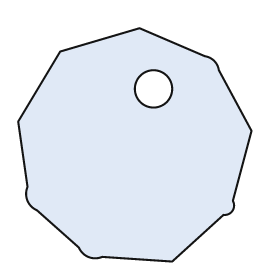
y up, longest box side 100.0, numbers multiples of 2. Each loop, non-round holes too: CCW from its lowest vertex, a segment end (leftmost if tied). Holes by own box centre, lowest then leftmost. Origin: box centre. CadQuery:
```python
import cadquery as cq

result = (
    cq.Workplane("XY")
    .moveTo(16.0, -50.0)
    .lineTo(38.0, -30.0)
    .threePointArc((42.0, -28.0), (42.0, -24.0))
    .lineTo(50.0, 6.0)
    .lineTo(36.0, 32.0)
    .threePointArc((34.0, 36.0), (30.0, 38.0))
    .lineTo(2.0, 50.0)
    .lineTo(-32.0, 40.0)
    .lineTo(-50.0, 10.0)
    .lineTo(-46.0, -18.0)
    .threePointArc((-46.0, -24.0), (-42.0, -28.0))
    .lineTo(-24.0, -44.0)
    .threePointArc((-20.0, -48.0), (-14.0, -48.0))
    .close()
    .moveTo(8.0, 24.0)
    .circle(8.0)
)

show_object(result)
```